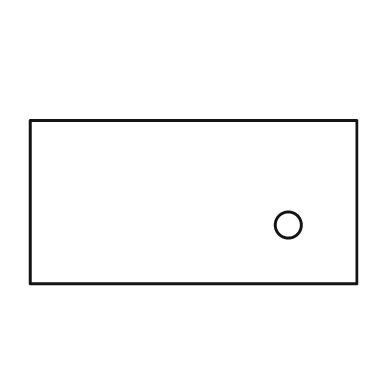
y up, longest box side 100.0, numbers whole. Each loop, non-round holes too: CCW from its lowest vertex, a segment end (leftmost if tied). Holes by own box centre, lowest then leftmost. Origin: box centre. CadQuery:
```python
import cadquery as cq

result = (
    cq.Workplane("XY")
    .moveTo(-50.0, -25.0)
    .lineTo(50.0, -25.0)
    .lineTo(50.0, 25.0)
    .lineTo(-50.0, 25.0)
    .close()
    .moveTo(29.0, -7.0)
    .circle(4.0)
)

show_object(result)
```